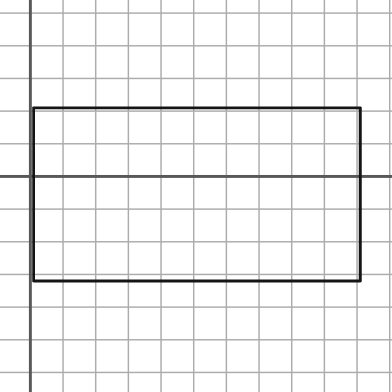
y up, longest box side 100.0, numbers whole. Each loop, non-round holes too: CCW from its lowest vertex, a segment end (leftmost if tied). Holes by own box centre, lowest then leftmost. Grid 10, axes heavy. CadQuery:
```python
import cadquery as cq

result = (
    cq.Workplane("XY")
    .moveTo(1.0, -32.0)
    .lineTo(101.0, -32.0)
    .lineTo(101.0, 21.0)
    .lineTo(1.0, 21.0)
    .close()
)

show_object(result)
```